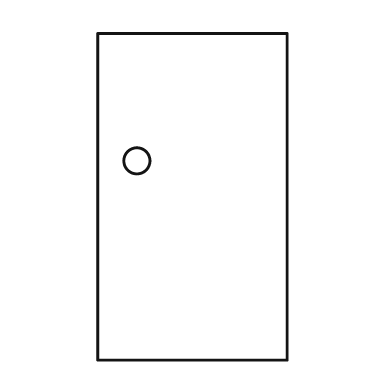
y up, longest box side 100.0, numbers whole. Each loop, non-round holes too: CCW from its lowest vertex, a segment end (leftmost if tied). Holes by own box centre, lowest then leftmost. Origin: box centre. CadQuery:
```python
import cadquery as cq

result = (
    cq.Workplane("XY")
    .moveTo(-29.0, -50.0)
    .lineTo(29.0, -50.0)
    .lineTo(29.0, 50.0)
    .lineTo(-29.0, 50.0)
    .close()
    .moveTo(-17.0, 11.0)
    .circle(4.0)
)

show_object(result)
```